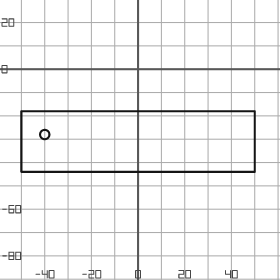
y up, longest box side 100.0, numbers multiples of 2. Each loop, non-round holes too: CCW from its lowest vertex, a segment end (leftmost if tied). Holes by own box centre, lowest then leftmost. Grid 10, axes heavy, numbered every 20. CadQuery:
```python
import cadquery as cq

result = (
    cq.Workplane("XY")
    .moveTo(-50.0, -44.0)
    .lineTo(50.0, -44.0)
    .lineTo(50.0, -18.0)
    .lineTo(-50.0, -18.0)
    .close()
    .moveTo(-40.0, -28.0)
    .circle(2.0)
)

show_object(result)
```